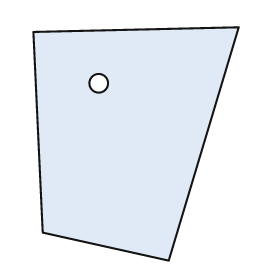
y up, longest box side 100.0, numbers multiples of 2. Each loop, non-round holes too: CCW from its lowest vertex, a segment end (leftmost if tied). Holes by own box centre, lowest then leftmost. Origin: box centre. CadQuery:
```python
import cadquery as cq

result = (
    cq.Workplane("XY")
    .moveTo(14.0, -50.0)
    .lineTo(44.0, 50.0)
    .lineTo(-44.0, 48.0)
    .lineTo(-40.0, -38.0)
    .close()
    .moveTo(-16.0, 26.0)
    .circle(4.0)
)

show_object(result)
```